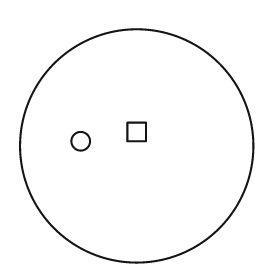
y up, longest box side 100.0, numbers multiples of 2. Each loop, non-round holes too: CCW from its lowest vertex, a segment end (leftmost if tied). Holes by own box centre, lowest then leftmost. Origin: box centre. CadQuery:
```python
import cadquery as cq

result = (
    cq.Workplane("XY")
    .moveTo(0.0, 0.0)
    .circle(50.0)
    .moveTo(-24.0, 2.0)
    .circle(4.0)
    .moveTo(-4.0, 2.0)
    .lineTo(4.0, 2.0)
    .lineTo(4.0, 10.0)
    .lineTo(-4.0, 10.0)
    .close()
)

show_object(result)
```